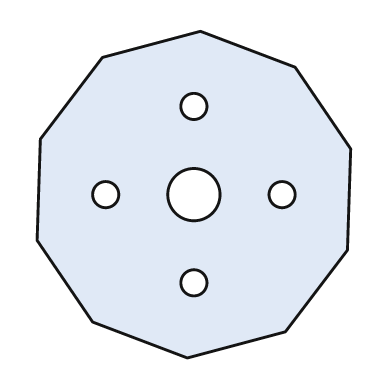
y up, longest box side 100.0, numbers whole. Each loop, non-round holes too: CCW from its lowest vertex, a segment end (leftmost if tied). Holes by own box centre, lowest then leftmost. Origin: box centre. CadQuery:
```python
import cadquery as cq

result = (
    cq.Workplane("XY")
    .moveTo(-2.0, -50.0)
    .lineTo(28.0, -42.0)
    .lineTo(47.0, -17.0)
    .lineTo(48.0, 14.0)
    .lineTo(31.0, 39.0)
    .lineTo(2.0, 50.0)
    .lineTo(-28.0, 42.0)
    .lineTo(-47.0, 17.0)
    .lineTo(-48.0, -14.0)
    .lineTo(-31.0, -39.0)
    .close()
    .moveTo(0.0, -27.0)
    .circle(4.0)
    .moveTo(-27.0, 0.0)
    .circle(4.0)
    .moveTo(0.0, 0.0)
    .circle(8.0)
    .moveTo(27.0, 0.0)
    .circle(4.0)
    .moveTo(0.0, 27.0)
    .circle(4.0)
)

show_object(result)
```